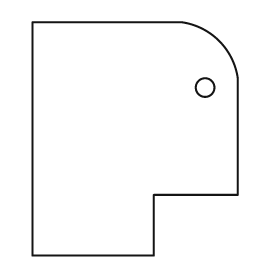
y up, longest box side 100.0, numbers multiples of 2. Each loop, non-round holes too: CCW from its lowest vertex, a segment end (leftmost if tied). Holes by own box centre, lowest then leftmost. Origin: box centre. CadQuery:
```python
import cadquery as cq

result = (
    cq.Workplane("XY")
    .moveTo(-44.0, -50.0)
    .lineTo(8.0, -50.0)
    .lineTo(8.0, -24.0)
    .lineTo(44.0, -24.0)
    .lineTo(44.0, 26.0)
    .threePointArc((36.0, 42.0), (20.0, 50.0))
    .lineTo(-44.0, 50.0)
    .close()
    .moveTo(30.0, 22.0)
    .circle(4.0)
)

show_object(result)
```